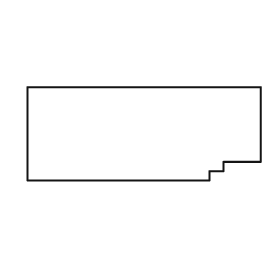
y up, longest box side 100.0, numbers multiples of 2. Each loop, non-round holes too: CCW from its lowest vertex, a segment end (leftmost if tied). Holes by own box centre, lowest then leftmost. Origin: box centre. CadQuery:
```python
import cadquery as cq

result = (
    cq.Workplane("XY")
    .moveTo(-50.0, -20.0)
    .lineTo(28.0, -20.0)
    .lineTo(28.0, -16.0)
    .lineTo(34.0, -16.0)
    .lineTo(34.0, -12.0)
    .lineTo(50.0, -12.0)
    .lineTo(50.0, 20.0)
    .lineTo(-50.0, 20.0)
    .close()
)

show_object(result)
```